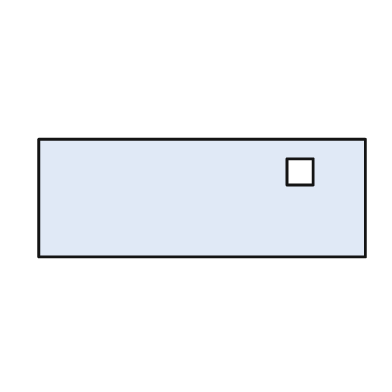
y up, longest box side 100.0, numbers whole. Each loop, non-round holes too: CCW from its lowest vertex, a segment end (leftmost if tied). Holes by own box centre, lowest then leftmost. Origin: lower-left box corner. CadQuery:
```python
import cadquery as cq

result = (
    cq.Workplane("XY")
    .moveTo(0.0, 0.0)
    .lineTo(100.0, 0.0)
    .lineTo(100.0, 36.0)
    .lineTo(0.0, 36.0)
    .close()
    .moveTo(76.0, 22.0)
    .lineTo(84.0, 22.0)
    .lineTo(84.0, 30.0)
    .lineTo(76.0, 30.0)
    .close()
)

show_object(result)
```